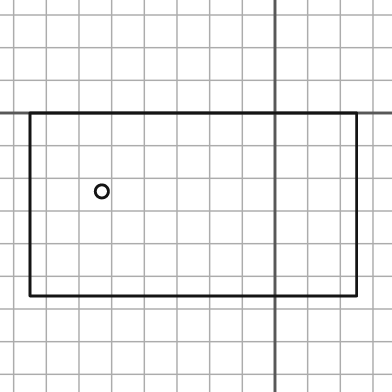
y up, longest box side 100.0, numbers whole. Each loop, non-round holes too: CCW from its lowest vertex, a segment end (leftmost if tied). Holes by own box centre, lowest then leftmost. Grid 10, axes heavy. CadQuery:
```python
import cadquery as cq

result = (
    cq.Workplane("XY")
    .moveTo(-75.0, -56.0)
    .lineTo(25.0, -56.0)
    .lineTo(25.0, 0.0)
    .lineTo(-75.0, 0.0)
    .close()
    .moveTo(-53.0, -24.0)
    .circle(2.0)
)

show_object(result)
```